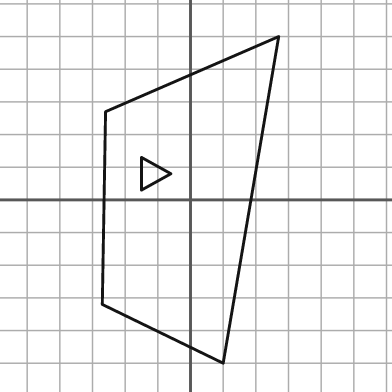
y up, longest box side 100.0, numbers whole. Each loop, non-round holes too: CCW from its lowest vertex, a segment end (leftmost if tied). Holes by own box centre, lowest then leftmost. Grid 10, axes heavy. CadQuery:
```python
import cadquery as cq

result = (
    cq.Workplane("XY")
    .moveTo(10.0, -50.0)
    .lineTo(27.0, 50.0)
    .lineTo(-26.0, 27.0)
    .lineTo(-27.0, -32.0)
    .close()
    .moveTo(-15.0, 3.0)
    .lineTo(-6.0, 8.0)
    .lineTo(-15.0, 13.0)
    .close()
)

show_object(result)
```